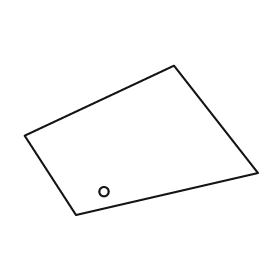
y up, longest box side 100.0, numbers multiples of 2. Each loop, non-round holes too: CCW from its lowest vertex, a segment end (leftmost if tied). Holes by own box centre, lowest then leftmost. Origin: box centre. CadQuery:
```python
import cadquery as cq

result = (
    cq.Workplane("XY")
    .moveTo(-28.0, -32.0)
    .lineTo(50.0, -14.0)
    .lineTo(14.0, 32.0)
    .lineTo(-50.0, 2.0)
    .close()
    .moveTo(-16.0, -22.0)
    .circle(2.0)
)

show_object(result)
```